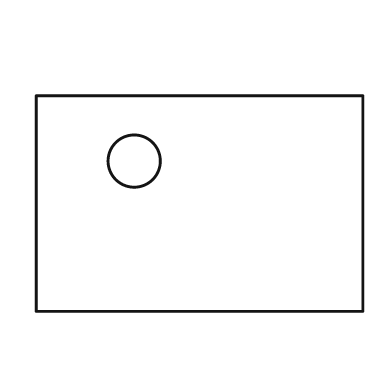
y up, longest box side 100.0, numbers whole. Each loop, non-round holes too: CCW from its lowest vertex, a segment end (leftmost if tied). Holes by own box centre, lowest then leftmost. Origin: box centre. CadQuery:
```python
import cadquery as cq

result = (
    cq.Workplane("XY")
    .moveTo(-50.0, -33.0)
    .lineTo(50.0, -33.0)
    .lineTo(50.0, 33.0)
    .lineTo(-50.0, 33.0)
    .close()
    .moveTo(-20.0, 13.0)
    .circle(8.0)
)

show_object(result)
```